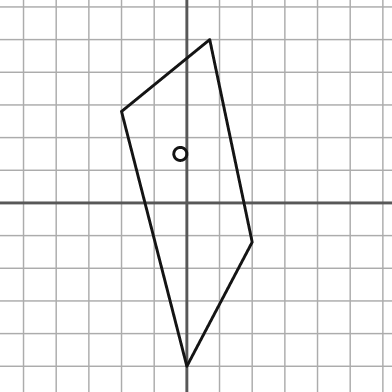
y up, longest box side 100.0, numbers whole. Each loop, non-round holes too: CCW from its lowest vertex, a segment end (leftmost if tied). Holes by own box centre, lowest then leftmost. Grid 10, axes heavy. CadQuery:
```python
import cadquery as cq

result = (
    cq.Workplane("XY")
    .moveTo(0.0, -50.0)
    .lineTo(20.0, -12.0)
    .lineTo(7.0, 50.0)
    .lineTo(-20.0, 28.0)
    .close()
    .moveTo(-2.0, 15.0)
    .circle(2.0)
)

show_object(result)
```